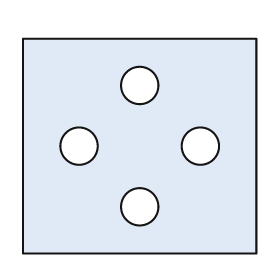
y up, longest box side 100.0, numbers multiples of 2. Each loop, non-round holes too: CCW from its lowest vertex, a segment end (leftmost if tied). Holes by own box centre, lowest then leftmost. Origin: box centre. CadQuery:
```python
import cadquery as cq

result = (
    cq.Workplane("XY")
    .moveTo(-50.0, -46.0)
    .lineTo(50.0, -46.0)
    .lineTo(50.0, 46.0)
    .lineTo(-50.0, 46.0)
    .close()
    .moveTo(0.0, -26.0)
    .circle(8.0)
    .moveTo(-26.0, 0.0)
    .circle(8.0)
    .moveTo(26.0, 0.0)
    .circle(8.0)
    .moveTo(0.0, 26.0)
    .circle(8.0)
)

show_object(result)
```